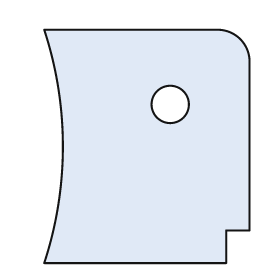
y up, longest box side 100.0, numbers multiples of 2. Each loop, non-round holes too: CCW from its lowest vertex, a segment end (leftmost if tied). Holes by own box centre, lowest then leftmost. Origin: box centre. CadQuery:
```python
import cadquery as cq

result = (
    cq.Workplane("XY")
    .moveTo(-44.0, -50.0)
    .lineTo(34.0, -50.0)
    .lineTo(34.0, -36.0)
    .lineTo(44.0, -36.0)
    .lineTo(44.0, 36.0)
    .threePointArc((40.0, 46.0), (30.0, 50.0))
    .lineTo(-44.0, 50.0)
    .threePointArc((-36.0, 0.0), (-44.0, -50.0))
    .close()
    .moveTo(10.0, 18.0)
    .circle(8.0)
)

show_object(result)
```